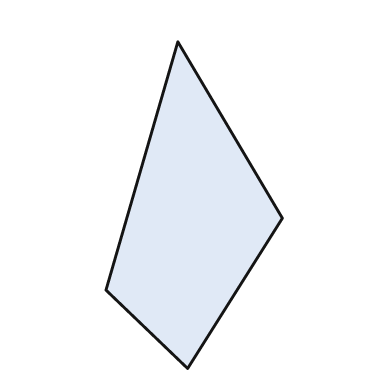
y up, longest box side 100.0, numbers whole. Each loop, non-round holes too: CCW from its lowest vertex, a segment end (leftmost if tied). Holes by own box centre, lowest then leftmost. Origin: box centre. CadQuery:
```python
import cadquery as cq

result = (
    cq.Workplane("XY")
    .moveTo(-2.0, -50.0)
    .lineTo(27.0, -4.0)
    .lineTo(-5.0, 50.0)
    .lineTo(-27.0, -26.0)
    .close()
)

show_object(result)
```